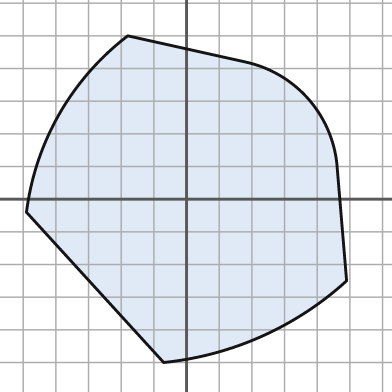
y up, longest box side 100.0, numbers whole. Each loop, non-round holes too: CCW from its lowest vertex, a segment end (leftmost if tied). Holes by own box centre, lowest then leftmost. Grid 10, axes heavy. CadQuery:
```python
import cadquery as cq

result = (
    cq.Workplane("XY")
    .moveTo(-7.0, -50.0)
    .threePointArc((23.0, -42.0), (49.0, -25.0))
    .lineTo(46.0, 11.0)
    .threePointArc((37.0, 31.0), (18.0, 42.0))
    .lineTo(-18.0, 50.0)
    .threePointArc((-39.0, 26.0), (-49.0, -4.0))
    .close()
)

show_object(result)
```